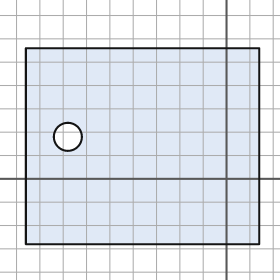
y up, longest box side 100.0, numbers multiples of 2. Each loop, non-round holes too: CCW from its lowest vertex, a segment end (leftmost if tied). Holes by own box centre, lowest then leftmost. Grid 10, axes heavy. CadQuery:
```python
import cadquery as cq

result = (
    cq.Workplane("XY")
    .moveTo(-86.0, -28.0)
    .lineTo(14.0, -28.0)
    .lineTo(14.0, 56.0)
    .lineTo(-86.0, 56.0)
    .close()
    .moveTo(-68.0, 18.0)
    .circle(6.0)
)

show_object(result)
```